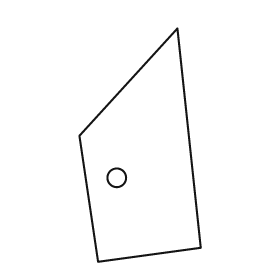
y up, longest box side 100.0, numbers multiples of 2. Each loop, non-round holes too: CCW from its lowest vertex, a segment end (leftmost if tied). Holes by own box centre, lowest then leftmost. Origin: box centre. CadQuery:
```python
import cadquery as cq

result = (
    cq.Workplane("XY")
    .moveTo(-18.0, -50.0)
    .lineTo(26.0, -44.0)
    .lineTo(16.0, 50.0)
    .lineTo(-26.0, 4.0)
    .close()
    .moveTo(-10.0, -14.0)
    .circle(4.0)
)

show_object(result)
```